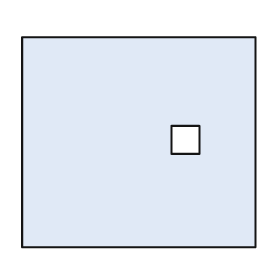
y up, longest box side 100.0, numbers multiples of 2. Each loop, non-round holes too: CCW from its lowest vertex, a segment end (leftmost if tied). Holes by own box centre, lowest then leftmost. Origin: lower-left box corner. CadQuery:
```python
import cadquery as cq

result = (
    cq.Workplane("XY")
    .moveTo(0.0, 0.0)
    .lineTo(100.0, 0.0)
    .lineTo(100.0, 90.0)
    .lineTo(0.0, 90.0)
    .close()
    .moveTo(64.0, 40.0)
    .lineTo(76.0, 40.0)
    .lineTo(76.0, 52.0)
    .lineTo(64.0, 52.0)
    .close()
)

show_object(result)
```